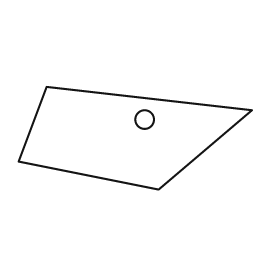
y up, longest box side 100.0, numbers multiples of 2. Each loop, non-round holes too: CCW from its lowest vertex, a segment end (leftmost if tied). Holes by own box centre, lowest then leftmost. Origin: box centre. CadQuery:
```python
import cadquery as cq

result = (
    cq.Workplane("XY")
    .moveTo(10.0, -22.0)
    .lineTo(50.0, 12.0)
    .lineTo(-38.0, 22.0)
    .lineTo(-50.0, -10.0)
    .close()
    .moveTo(4.0, 8.0)
    .circle(4.0)
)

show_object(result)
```